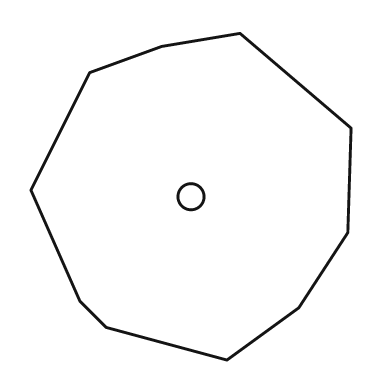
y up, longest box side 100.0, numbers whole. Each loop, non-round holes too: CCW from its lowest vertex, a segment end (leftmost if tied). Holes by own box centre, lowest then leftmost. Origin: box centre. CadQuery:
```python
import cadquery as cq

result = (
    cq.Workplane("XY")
    .moveTo(11.0, -50.0)
    .lineTo(33.0, -34.0)
    .lineTo(48.0, -11.0)
    .lineTo(49.0, 21.0)
    .lineTo(15.0, 50.0)
    .lineTo(-9.0, 46.0)
    .lineTo(-31.0, 38.0)
    .lineTo(-49.0, 2.0)
    .lineTo(-34.0, -32.0)
    .lineTo(-26.0, -40.0)
    .close()
    .moveTo(0.0, 0.0)
    .circle(4.0)
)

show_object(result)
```